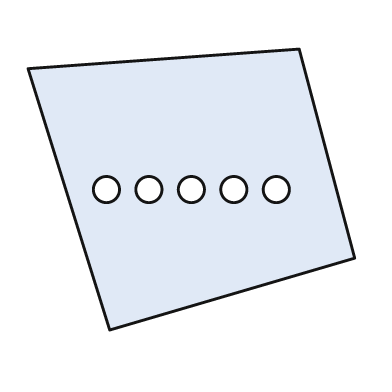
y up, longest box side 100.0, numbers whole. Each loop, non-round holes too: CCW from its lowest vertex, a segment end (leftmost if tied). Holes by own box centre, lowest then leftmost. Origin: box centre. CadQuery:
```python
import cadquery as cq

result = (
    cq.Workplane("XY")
    .moveTo(-25.0, -43.0)
    .lineTo(50.0, -21.0)
    .lineTo(33.0, 43.0)
    .lineTo(-50.0, 37.0)
    .close()
    .moveTo(-26.0, 0.0)
    .circle(4.0)
    .moveTo(-13.0, 0.0)
    .circle(4.0)
    .moveTo(0.0, 0.0)
    .circle(4.0)
    .moveTo(13.0, 0.0)
    .circle(4.0)
    .moveTo(26.0, 0.0)
    .circle(4.0)
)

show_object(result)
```